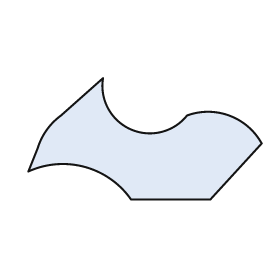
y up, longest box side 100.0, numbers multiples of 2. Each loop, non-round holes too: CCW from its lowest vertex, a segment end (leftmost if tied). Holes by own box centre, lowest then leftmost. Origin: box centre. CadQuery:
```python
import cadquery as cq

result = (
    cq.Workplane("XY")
    .moveTo(-6.0, -26.0)
    .lineTo(28.0, -26.0)
    .lineTo(50.0, -2.0)
    .threePointArc((36.0, 10.0), (18.0, 10.0))
    .threePointArc((-6.0, 4.0), (-18.0, 26.0))
    .lineTo(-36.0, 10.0)
    .threePointArc((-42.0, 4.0), (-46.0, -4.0))
    .lineTo(-50.0, -14.0)
    .threePointArc((-26.0, -12.0), (-6.0, -26.0))
    .close()
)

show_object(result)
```